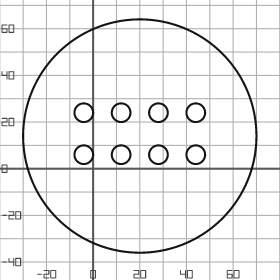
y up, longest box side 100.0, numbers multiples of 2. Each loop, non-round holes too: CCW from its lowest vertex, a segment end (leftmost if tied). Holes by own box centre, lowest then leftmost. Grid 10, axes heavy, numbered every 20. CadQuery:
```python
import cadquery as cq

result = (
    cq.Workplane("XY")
    .moveTo(20.0, 14.0)
    .circle(50.0)
    .moveTo(-4.0, 6.0)
    .circle(4.0)
    .moveTo(12.0, 6.0)
    .circle(4.0)
    .moveTo(28.0, 6.0)
    .circle(4.0)
    .moveTo(44.0, 6.0)
    .circle(4.0)
    .moveTo(-4.0, 24.0)
    .circle(4.0)
    .moveTo(12.0, 24.0)
    .circle(4.0)
    .moveTo(28.0, 24.0)
    .circle(4.0)
    .moveTo(44.0, 24.0)
    .circle(4.0)
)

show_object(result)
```